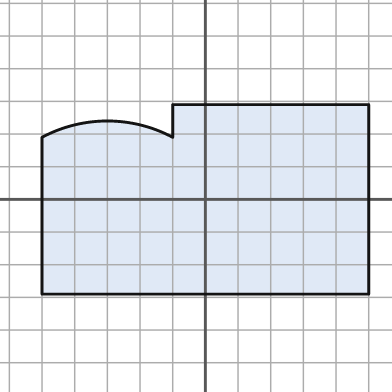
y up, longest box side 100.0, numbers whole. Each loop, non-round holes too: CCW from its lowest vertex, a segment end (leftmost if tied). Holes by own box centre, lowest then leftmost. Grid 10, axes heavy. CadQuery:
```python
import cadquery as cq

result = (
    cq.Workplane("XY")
    .moveTo(-50.0, -29.0)
    .lineTo(50.0, -29.0)
    .lineTo(50.0, 29.0)
    .lineTo(-10.0, 29.0)
    .lineTo(-10.0, 19.0)
    .threePointArc((-30.0, 24.0), (-50.0, 19.0))
    .close()
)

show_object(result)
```